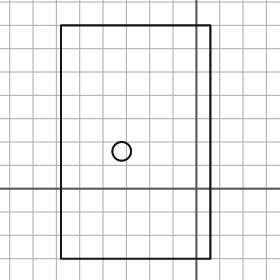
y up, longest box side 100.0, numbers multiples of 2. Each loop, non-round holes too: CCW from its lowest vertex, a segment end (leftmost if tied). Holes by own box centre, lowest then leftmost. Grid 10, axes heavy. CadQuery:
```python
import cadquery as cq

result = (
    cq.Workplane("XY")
    .moveTo(-58.0, -30.0)
    .lineTo(6.0, -30.0)
    .lineTo(6.0, 70.0)
    .lineTo(-58.0, 70.0)
    .close()
    .moveTo(-32.0, 16.0)
    .circle(4.0)
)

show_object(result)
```